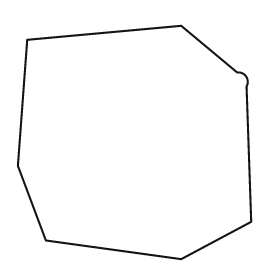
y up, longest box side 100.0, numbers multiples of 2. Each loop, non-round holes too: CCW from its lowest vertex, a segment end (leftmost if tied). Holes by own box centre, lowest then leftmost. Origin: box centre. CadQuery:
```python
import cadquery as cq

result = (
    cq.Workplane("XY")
    .moveTo(20.0, -50.0)
    .lineTo(50.0, -34.0)
    .lineTo(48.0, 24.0)
    .threePointArc((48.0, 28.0), (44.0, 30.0))
    .lineTo(20.0, 50.0)
    .lineTo(-46.0, 44.0)
    .lineTo(-50.0, -10.0)
    .lineTo(-38.0, -42.0)
    .close()
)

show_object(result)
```